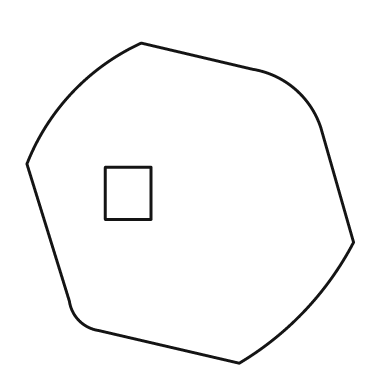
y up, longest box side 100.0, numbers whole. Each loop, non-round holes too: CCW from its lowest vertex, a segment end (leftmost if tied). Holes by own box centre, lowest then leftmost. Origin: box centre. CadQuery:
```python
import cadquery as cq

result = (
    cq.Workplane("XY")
    .moveTo(15.0, -49.0)
    .threePointArc((35.0, -33.0), (50.0, -12.0))
    .lineTo(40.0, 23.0)
    .threePointArc((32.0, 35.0), (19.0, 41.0))
    .lineTo(-15.0, 49.0)
    .threePointArc((-36.0, 34.0), (-50.0, 12.0))
    .lineTo(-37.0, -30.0)
    .threePointArc((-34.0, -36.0), (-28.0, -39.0))
    .close()
    .moveTo(-26.0, -5.0)
    .lineTo(-12.0, -5.0)
    .lineTo(-12.0, 11.0)
    .lineTo(-26.0, 11.0)
    .close()
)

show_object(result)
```